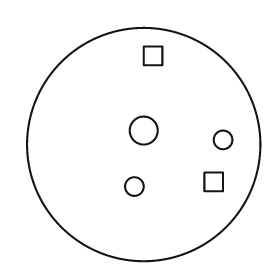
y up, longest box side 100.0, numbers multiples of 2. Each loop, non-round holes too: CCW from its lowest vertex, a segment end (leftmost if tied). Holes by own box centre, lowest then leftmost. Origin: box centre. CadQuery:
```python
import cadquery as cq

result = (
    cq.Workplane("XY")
    .moveTo(0.0, 0.0)
    .circle(50.0)
    .moveTo(-4.0, -18.0)
    .circle(4.0)
    .moveTo(26.0, -20.0)
    .lineTo(34.0, -20.0)
    .lineTo(34.0, -12.0)
    .lineTo(26.0, -12.0)
    .close()
    .moveTo(34.0, 2.0)
    .circle(4.0)
    .moveTo(0.0, 6.0)
    .circle(6.0)
    .moveTo(0.0, 34.0)
    .lineTo(8.0, 34.0)
    .lineTo(8.0, 42.0)
    .lineTo(0.0, 42.0)
    .close()
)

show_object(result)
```